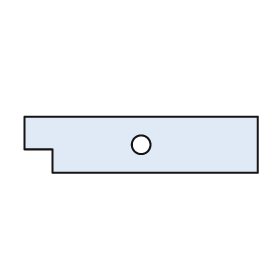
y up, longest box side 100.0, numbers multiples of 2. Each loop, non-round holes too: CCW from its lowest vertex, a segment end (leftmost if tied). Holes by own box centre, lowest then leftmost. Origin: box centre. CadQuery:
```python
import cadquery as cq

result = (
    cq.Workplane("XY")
    .moveTo(-38.0, -12.0)
    .lineTo(50.0, -12.0)
    .lineTo(50.0, 12.0)
    .lineTo(-50.0, 12.0)
    .lineTo(-50.0, -2.0)
    .lineTo(-38.0, -2.0)
    .close()
    .moveTo(0.0, 0.0)
    .circle(4.0)
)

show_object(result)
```